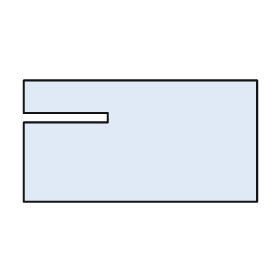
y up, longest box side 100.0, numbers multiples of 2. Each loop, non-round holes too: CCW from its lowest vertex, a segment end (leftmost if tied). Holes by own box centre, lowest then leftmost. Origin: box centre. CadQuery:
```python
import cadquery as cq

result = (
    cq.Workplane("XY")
    .moveTo(-50.0, -26.0)
    .lineTo(50.0, -26.0)
    .lineTo(50.0, 26.0)
    .lineTo(-50.0, 26.0)
    .lineTo(-50.0, 12.0)
    .lineTo(-14.0, 12.0)
    .lineTo(-14.0, 8.0)
    .lineTo(-50.0, 8.0)
    .close()
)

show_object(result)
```